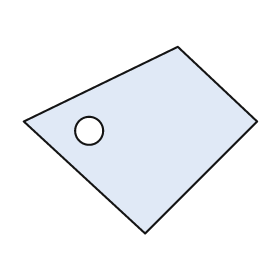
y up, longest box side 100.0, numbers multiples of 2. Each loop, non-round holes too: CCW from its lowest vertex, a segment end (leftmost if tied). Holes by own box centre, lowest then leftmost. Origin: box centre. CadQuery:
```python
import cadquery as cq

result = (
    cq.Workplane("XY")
    .moveTo(2.0, -40.0)
    .lineTo(50.0, 8.0)
    .lineTo(16.0, 40.0)
    .lineTo(-50.0, 8.0)
    .close()
    .moveTo(-22.0, 4.0)
    .circle(6.0)
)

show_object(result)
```